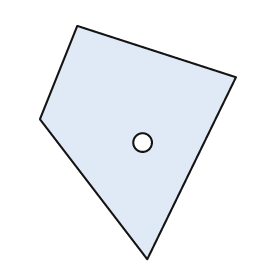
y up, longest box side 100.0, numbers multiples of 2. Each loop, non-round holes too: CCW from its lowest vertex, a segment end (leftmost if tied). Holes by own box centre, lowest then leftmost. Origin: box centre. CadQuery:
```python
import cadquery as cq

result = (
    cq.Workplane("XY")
    .moveTo(4.0, -50.0)
    .lineTo(42.0, 28.0)
    .lineTo(-26.0, 50.0)
    .lineTo(-42.0, 10.0)
    .close()
    .moveTo(2.0, 0.0)
    .circle(4.0)
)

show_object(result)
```